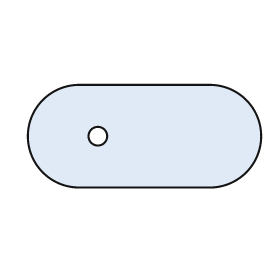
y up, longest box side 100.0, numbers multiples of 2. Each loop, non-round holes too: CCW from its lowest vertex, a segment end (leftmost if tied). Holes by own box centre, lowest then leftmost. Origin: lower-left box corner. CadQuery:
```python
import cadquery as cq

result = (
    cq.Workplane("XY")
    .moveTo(22.0, 0.0)
    .lineTo(78.0, 0.0)
    .threePointArc((100.0, 22.0), (78.0, 44.0))
    .lineTo(22.0, 44.0)
    .threePointArc((0.0, 22.0), (22.0, 0.0))
    .close()
    .moveTo(30.0, 22.0)
    .circle(4.0)
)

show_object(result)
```